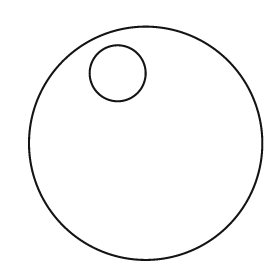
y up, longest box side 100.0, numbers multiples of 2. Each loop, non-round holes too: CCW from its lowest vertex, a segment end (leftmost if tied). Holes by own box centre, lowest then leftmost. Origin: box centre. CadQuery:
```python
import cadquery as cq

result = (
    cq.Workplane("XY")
    .moveTo(0.0, 0.0)
    .circle(50.0)
    .moveTo(-12.0, 30.0)
    .circle(12.0)
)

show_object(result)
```